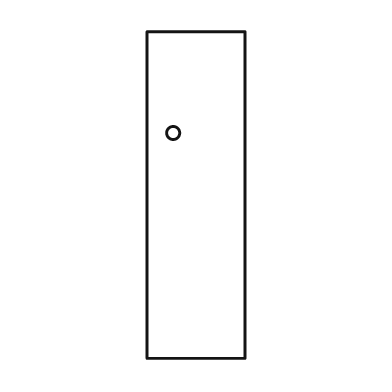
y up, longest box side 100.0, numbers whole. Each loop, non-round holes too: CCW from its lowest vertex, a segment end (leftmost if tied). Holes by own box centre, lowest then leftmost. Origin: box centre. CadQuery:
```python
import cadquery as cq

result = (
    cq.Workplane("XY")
    .moveTo(-15.0, -50.0)
    .lineTo(15.0, -50.0)
    .lineTo(15.0, 50.0)
    .lineTo(-15.0, 50.0)
    .close()
    .moveTo(-7.0, 19.0)
    .circle(2.0)
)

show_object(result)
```